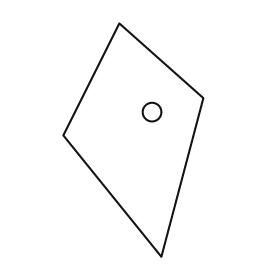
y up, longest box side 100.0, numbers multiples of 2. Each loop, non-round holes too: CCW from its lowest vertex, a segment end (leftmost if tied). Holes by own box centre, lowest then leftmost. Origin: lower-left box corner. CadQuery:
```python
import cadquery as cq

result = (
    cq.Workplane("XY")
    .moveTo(42.0, 0.0)
    .lineTo(60.0, 68.0)
    .lineTo(24.0, 100.0)
    .lineTo(0.0, 52.0)
    .close()
    .moveTo(38.0, 62.0)
    .circle(4.0)
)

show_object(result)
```